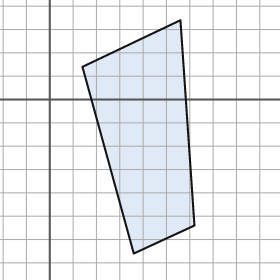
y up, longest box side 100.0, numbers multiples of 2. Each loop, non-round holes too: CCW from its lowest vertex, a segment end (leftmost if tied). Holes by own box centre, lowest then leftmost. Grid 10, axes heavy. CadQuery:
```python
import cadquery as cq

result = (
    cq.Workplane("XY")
    .moveTo(36.0, -66.0)
    .lineTo(62.0, -54.0)
    .lineTo(56.0, 34.0)
    .lineTo(14.0, 14.0)
    .close()
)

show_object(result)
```